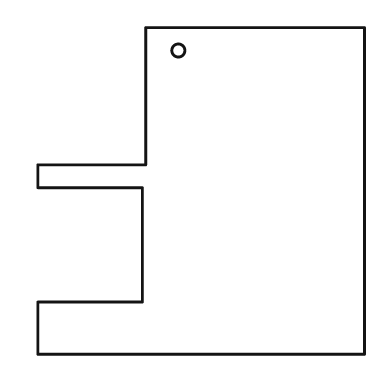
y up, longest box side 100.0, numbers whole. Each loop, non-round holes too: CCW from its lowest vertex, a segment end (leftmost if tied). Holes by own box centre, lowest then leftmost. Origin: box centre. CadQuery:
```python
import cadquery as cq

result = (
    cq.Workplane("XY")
    .moveTo(-50.0, -50.0)
    .lineTo(50.0, -50.0)
    .lineTo(50.0, 50.0)
    .lineTo(-17.0, 50.0)
    .lineTo(-17.0, 8.0)
    .lineTo(-50.0, 8.0)
    .lineTo(-50.0, 1.0)
    .lineTo(-18.0, 1.0)
    .lineTo(-18.0, -34.0)
    .lineTo(-50.0, -34.0)
    .close()
    .moveTo(-7.0, 43.0)
    .circle(2.0)
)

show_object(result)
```